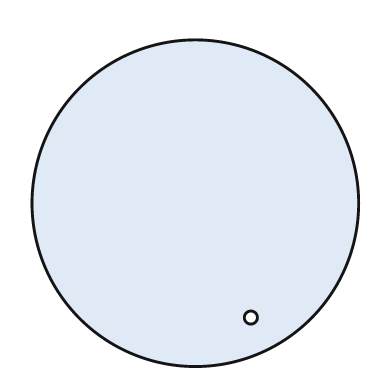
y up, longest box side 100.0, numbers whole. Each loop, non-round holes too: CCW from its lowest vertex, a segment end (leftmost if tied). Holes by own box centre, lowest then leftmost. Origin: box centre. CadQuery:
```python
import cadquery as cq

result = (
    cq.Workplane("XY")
    .moveTo(0.0, 0.0)
    .circle(50.0)
    .moveTo(17.0, -35.0)
    .circle(2.0)
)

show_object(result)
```